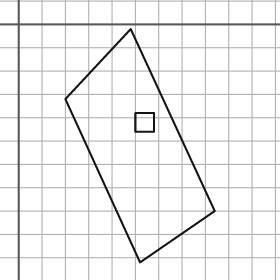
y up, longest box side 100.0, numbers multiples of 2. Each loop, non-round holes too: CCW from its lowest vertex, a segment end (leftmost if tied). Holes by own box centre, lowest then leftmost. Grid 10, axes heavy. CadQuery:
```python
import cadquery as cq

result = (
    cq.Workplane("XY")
    .moveTo(52.0, -102.0)
    .lineTo(84.0, -80.0)
    .lineTo(48.0, -2.0)
    .lineTo(20.0, -32.0)
    .close()
    .moveTo(50.0, -46.0)
    .lineTo(58.0, -46.0)
    .lineTo(58.0, -38.0)
    .lineTo(50.0, -38.0)
    .close()
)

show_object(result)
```